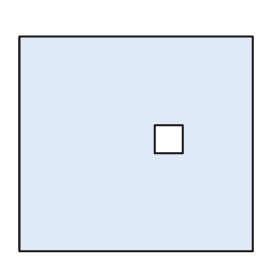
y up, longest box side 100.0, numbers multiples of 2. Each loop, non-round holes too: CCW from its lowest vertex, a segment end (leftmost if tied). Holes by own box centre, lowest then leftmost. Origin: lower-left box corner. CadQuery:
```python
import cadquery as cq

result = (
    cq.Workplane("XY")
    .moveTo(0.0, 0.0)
    .lineTo(100.0, 0.0)
    .lineTo(100.0, 92.0)
    .lineTo(0.0, 92.0)
    .close()
    .moveTo(58.0, 42.0)
    .lineTo(70.0, 42.0)
    .lineTo(70.0, 54.0)
    .lineTo(58.0, 54.0)
    .close()
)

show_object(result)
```